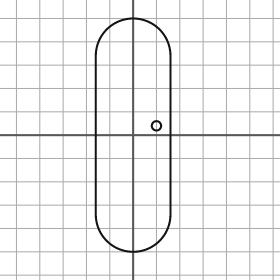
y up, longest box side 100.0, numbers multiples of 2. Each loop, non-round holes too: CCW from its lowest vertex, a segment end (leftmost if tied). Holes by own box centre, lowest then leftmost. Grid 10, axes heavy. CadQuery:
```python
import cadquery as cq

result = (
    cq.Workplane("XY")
    .moveTo(-16.0, -34.0)
    .threePointArc((0.0, -50.0), (16.0, -34.0))
    .lineTo(16.0, 34.0)
    .threePointArc((0.0, 50.0), (-16.0, 34.0))
    .close()
    .moveTo(10.0, 4.0)
    .circle(2.0)
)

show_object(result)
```